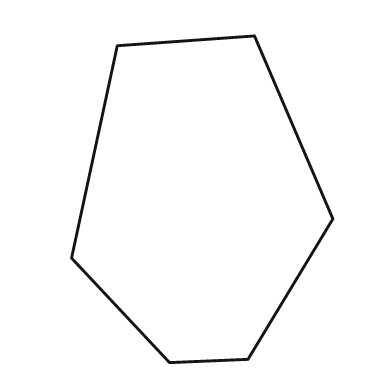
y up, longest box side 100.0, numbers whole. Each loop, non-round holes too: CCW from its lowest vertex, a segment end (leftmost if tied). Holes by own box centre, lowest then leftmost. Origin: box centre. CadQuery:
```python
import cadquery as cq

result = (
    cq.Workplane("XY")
    .moveTo(-10.0, -50.0)
    .lineTo(14.0, -49.0)
    .lineTo(40.0, -6.0)
    .lineTo(16.0, 50.0)
    .lineTo(-26.0, 47.0)
    .lineTo(-40.0, -18.0)
    .close()
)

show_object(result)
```